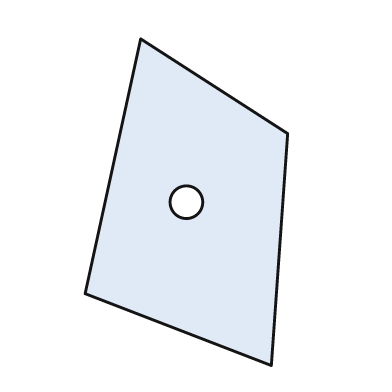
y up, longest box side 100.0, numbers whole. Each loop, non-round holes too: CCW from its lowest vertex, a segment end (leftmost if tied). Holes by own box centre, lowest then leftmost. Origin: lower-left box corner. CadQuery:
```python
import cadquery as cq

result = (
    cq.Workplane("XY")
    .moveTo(57.0, 0.0)
    .lineTo(62.0, 71.0)
    .lineTo(17.0, 100.0)
    .lineTo(0.0, 22.0)
    .close()
    .moveTo(31.0, 50.0)
    .circle(5.0)
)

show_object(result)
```